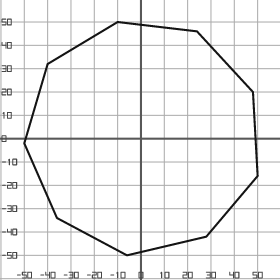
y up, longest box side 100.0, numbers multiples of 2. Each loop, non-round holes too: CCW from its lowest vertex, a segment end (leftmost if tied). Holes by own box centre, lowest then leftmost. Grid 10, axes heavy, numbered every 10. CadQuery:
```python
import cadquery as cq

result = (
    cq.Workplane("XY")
    .moveTo(-6.0, -50.0)
    .lineTo(28.0, -42.0)
    .lineTo(50.0, -16.0)
    .lineTo(48.0, 20.0)
    .lineTo(24.0, 46.0)
    .lineTo(-10.0, 50.0)
    .lineTo(-40.0, 32.0)
    .lineTo(-50.0, -2.0)
    .lineTo(-36.0, -34.0)
    .close()
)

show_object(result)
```